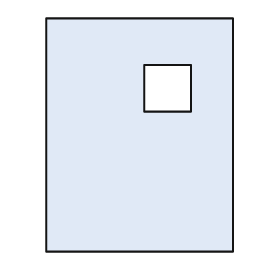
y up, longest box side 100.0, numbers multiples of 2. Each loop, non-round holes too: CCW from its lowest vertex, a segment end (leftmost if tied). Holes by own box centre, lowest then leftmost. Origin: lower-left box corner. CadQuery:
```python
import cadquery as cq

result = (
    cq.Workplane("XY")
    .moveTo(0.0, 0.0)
    .lineTo(80.0, 0.0)
    .lineTo(80.0, 100.0)
    .lineTo(0.0, 100.0)
    .close()
    .moveTo(42.0, 60.0)
    .lineTo(62.0, 60.0)
    .lineTo(62.0, 80.0)
    .lineTo(42.0, 80.0)
    .close()
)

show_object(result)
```